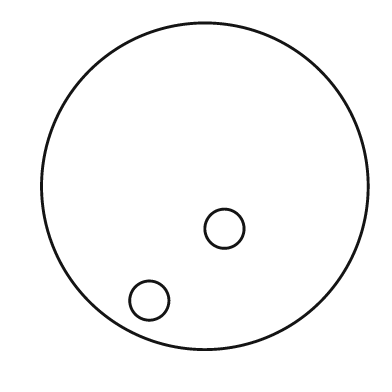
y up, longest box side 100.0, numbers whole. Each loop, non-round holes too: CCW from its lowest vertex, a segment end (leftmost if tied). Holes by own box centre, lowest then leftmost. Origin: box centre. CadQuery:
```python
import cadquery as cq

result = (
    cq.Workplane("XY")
    .moveTo(0.0, 0.0)
    .circle(50.0)
    .moveTo(-17.0, -35.0)
    .circle(6.0)
    .moveTo(6.0, -13.0)
    .circle(6.0)
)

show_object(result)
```